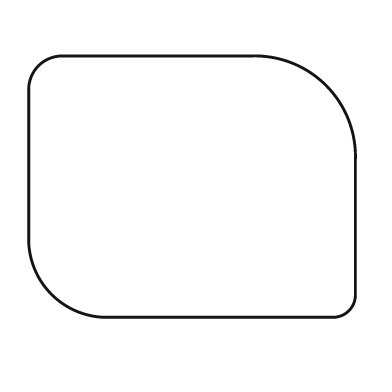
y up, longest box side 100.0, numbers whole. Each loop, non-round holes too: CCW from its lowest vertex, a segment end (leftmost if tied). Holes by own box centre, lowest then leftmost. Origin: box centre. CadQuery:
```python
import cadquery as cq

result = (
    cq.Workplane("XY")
    .moveTo(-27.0, -40.0)
    .lineTo(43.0, -40.0)
    .threePointArc((48.0, -38.0), (50.0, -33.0))
    .lineTo(50.0, 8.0)
    .threePointArc((41.0, 31.0), (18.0, 40.0))
    .lineTo(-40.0, 40.0)
    .threePointArc((-47.0, 37.0), (-50.0, 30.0))
    .lineTo(-50.0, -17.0)
    .threePointArc((-43.0, -33.0), (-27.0, -40.0))
    .close()
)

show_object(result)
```